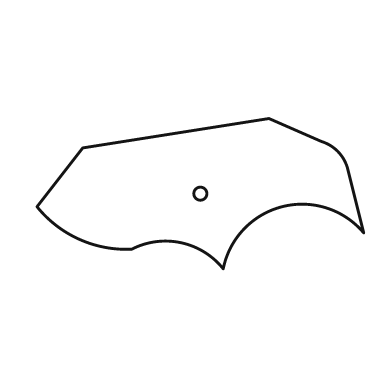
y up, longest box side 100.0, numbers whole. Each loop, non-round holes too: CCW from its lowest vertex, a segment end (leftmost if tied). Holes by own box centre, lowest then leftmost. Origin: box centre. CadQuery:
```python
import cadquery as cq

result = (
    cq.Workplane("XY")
    .moveTo(7.0, -23.0)
    .threePointArc((25.0, -4.0), (50.0, -12.0))
    .lineTo(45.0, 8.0)
    .threePointArc((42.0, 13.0), (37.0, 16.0))
    .lineTo(21.0, 23.0)
    .lineTo(-36.0, 14.0)
    .lineTo(-50.0, -4.0)
    .threePointArc((-37.0, -14.0), (-21.0, -17.0))
    .threePointArc((-6.0, -15.0), (7.0, -23.0))
    .close()
    .moveTo(0.0, 0.0)
    .circle(2.0)
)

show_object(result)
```